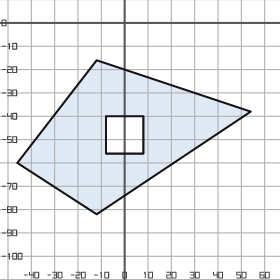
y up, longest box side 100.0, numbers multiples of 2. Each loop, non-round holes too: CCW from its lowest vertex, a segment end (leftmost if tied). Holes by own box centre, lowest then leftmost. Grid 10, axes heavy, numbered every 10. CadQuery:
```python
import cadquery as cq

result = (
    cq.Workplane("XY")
    .moveTo(-12.0, -82.0)
    .lineTo(54.0, -38.0)
    .lineTo(-12.0, -16.0)
    .lineTo(-46.0, -60.0)
    .close()
    .moveTo(-8.0, -56.0)
    .lineTo(8.0, -56.0)
    .lineTo(8.0, -40.0)
    .lineTo(-8.0, -40.0)
    .close()
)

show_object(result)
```